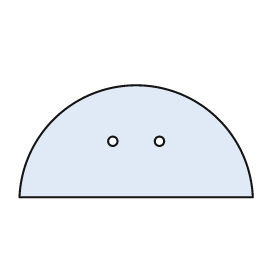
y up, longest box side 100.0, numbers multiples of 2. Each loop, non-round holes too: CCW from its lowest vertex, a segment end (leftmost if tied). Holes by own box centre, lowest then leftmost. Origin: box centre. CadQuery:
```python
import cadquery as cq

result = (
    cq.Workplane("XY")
    .moveTo(-50.0, -24.0)
    .lineTo(50.0, -24.0)
    .threePointArc((0.0, 24.0), (-50.0, -24.0))
    .close()
    .moveTo(-10.0, 0.0)
    .circle(2.0)
    .moveTo(10.0, 0.0)
    .circle(2.0)
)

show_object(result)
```